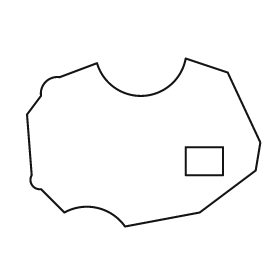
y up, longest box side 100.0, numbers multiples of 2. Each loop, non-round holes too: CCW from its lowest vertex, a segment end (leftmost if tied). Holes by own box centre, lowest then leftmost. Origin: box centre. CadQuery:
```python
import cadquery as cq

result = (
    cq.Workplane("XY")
    .moveTo(-8.0, -36.0)
    .lineTo(24.0, -30.0)
    .lineTo(48.0, -12.0)
    .lineTo(50.0, 0.0)
    .lineTo(36.0, 30.0)
    .lineTo(18.0, 36.0)
    .threePointArc((0.0, 20.0), (-20.0, 34.0))
    .lineTo(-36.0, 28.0)
    .threePointArc((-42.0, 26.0), (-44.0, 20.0))
    .lineTo(-50.0, 12.0)
    .lineTo(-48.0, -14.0)
    .threePointArc((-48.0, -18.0), (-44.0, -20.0))
    .lineTo(-34.0, -30.0)
    .threePointArc((-20.0, -28.0), (-8.0, -36.0))
    .close()
    .moveTo(18.0, -14.0)
    .lineTo(34.0, -14.0)
    .lineTo(34.0, -2.0)
    .lineTo(18.0, -2.0)
    .close()
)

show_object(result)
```